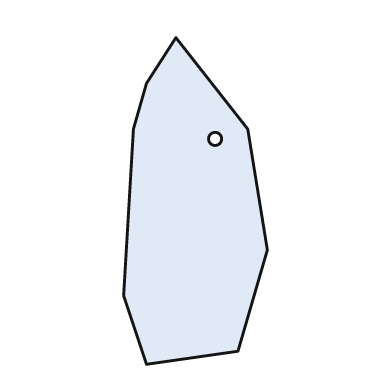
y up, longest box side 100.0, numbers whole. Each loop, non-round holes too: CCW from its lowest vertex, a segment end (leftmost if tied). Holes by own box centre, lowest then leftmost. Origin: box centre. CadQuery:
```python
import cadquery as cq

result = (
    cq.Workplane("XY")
    .moveTo(-15.0, -50.0)
    .lineTo(13.0, -46.0)
    .lineTo(22.0, -15.0)
    .lineTo(16.0, 22.0)
    .lineTo(-6.0, 50.0)
    .lineTo(-15.0, 36.0)
    .lineTo(-19.0, 22.0)
    .lineTo(-22.0, -29.0)
    .close()
    .moveTo(6.0, 19.0)
    .circle(2.0)
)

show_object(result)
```